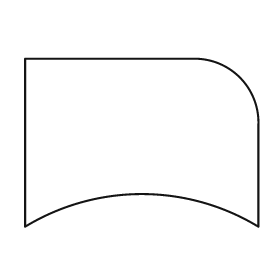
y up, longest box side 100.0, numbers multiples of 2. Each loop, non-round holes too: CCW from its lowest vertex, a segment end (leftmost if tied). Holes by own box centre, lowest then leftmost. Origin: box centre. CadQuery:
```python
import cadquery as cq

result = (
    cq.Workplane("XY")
    .moveTo(-50.0, -36.0)
    .threePointArc((0.0, -22.0), (50.0, -36.0))
    .lineTo(50.0, 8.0)
    .threePointArc((42.0, 28.0), (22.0, 36.0))
    .lineTo(-50.0, 36.0)
    .close()
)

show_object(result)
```